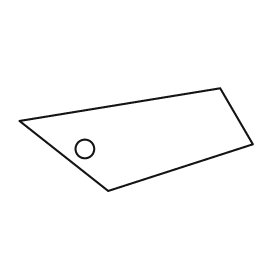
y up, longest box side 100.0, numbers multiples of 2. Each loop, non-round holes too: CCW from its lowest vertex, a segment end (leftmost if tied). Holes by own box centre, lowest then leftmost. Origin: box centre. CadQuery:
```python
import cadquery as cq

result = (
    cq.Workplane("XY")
    .moveTo(-12.0, -22.0)
    .lineTo(50.0, -2.0)
    .lineTo(36.0, 22.0)
    .lineTo(-50.0, 8.0)
    .close()
    .moveTo(-22.0, -4.0)
    .circle(4.0)
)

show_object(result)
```